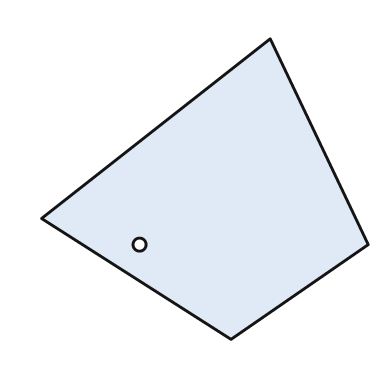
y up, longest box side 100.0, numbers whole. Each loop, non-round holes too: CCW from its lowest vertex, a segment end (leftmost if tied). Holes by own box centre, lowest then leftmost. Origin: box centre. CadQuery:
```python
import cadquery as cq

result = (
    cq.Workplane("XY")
    .moveTo(8.0, -46.0)
    .lineTo(50.0, -17.0)
    .lineTo(20.0, 46.0)
    .lineTo(-50.0, -9.0)
    .close()
    .moveTo(-20.0, -17.0)
    .circle(2.0)
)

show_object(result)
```